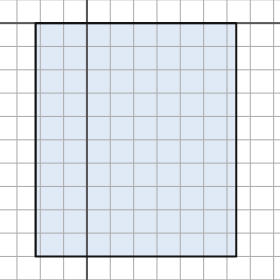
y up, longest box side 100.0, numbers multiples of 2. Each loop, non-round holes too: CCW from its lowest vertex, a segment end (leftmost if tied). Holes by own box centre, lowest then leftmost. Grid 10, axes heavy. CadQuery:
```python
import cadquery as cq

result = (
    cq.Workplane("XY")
    .moveTo(-22.0, -100.0)
    .lineTo(64.0, -100.0)
    .lineTo(64.0, 0.0)
    .lineTo(-22.0, 0.0)
    .close()
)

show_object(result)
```